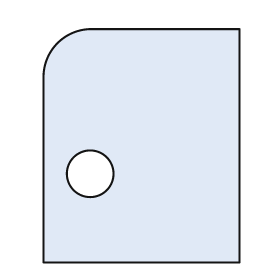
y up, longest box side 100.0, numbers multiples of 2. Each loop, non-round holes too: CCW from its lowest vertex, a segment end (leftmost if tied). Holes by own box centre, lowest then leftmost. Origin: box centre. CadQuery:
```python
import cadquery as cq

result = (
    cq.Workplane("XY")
    .moveTo(-42.0, -50.0)
    .lineTo(42.0, -50.0)
    .lineTo(42.0, 50.0)
    .lineTo(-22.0, 50.0)
    .threePointArc((-36.0, 44.0), (-42.0, 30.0))
    .close()
    .moveTo(-22.0, -12.0)
    .circle(10.0)
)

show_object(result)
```